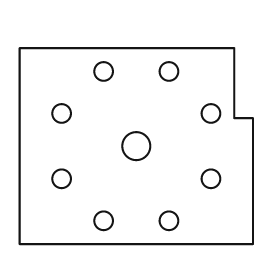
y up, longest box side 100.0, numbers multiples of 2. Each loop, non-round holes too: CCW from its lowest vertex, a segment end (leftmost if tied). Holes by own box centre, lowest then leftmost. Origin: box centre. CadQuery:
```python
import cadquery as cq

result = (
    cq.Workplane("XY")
    .moveTo(-50.0, -42.0)
    .lineTo(50.0, -42.0)
    .lineTo(50.0, 12.0)
    .lineTo(42.0, 12.0)
    .lineTo(42.0, 42.0)
    .lineTo(-50.0, 42.0)
    .close()
    .moveTo(-14.0, -32.0)
    .circle(4.0)
    .moveTo(14.0, -32.0)
    .circle(4.0)
    .moveTo(-32.0, -14.0)
    .circle(4.0)
    .moveTo(32.0, -14.0)
    .circle(4.0)
    .moveTo(0.0, 0.0)
    .circle(6.0)
    .moveTo(-32.0, 14.0)
    .circle(4.0)
    .moveTo(32.0, 14.0)
    .circle(4.0)
    .moveTo(-14.0, 32.0)
    .circle(4.0)
    .moveTo(14.0, 32.0)
    .circle(4.0)
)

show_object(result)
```